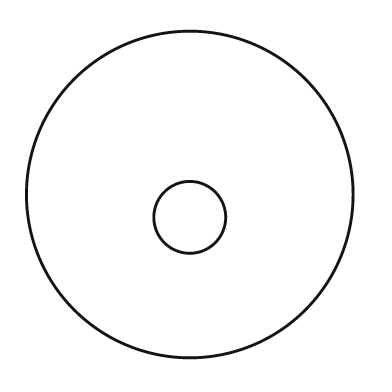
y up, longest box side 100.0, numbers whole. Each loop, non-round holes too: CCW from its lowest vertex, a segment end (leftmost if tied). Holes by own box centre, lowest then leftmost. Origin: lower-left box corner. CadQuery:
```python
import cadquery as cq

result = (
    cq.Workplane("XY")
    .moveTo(50.0, 50.0)
    .circle(50.0)
    .moveTo(50.0, 43.0)
    .circle(11.0)
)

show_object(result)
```